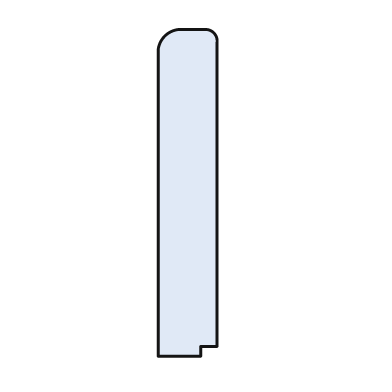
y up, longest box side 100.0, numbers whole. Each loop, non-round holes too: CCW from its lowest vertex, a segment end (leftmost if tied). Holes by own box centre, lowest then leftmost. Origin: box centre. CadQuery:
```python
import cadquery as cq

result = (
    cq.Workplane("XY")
    .moveTo(-9.0, -50.0)
    .lineTo(4.0, -50.0)
    .lineTo(4.0, -47.0)
    .lineTo(9.0, -47.0)
    .lineTo(9.0, 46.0)
    .threePointArc((8.0, 49.0), (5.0, 50.0))
    .lineTo(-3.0, 50.0)
    .threePointArc((-7.0, 48.0), (-9.0, 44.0))
    .close()
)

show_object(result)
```